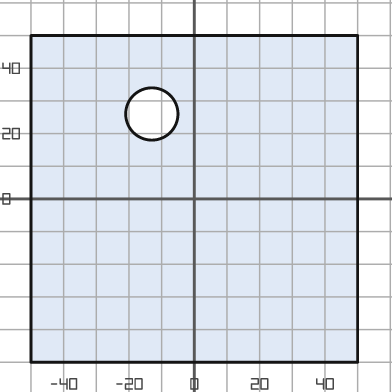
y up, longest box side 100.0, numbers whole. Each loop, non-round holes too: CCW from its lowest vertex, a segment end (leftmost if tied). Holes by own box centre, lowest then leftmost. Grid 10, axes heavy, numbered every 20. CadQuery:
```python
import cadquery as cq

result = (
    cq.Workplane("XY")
    .moveTo(-50.0, -50.0)
    .lineTo(50.0, -50.0)
    .lineTo(50.0, 50.0)
    .lineTo(-50.0, 50.0)
    .close()
    .moveTo(-13.0, 26.0)
    .circle(8.0)
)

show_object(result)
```